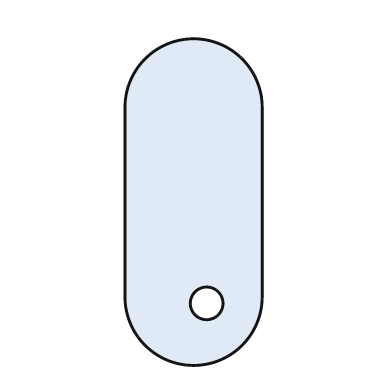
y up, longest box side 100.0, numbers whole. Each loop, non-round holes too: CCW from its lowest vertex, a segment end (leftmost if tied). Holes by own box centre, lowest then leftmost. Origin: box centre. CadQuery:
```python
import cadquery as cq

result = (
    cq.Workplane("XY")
    .moveTo(-21.0, -29.0)
    .threePointArc((0.0, -50.0), (21.0, -29.0))
    .lineTo(21.0, 29.0)
    .threePointArc((0.0, 50.0), (-21.0, 29.0))
    .close()
    .moveTo(4.0, -31.0)
    .circle(5.0)
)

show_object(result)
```